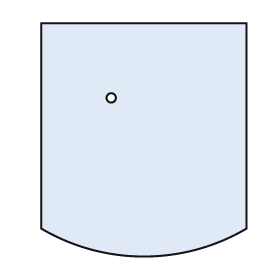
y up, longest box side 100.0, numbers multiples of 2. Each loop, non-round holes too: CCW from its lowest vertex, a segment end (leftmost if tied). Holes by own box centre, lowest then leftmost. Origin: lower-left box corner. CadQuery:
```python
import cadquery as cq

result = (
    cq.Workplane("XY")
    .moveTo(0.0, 12.0)
    .threePointArc((44.0, 0.0), (88.0, 12.0))
    .lineTo(88.0, 100.0)
    .lineTo(0.0, 100.0)
    .close()
    .moveTo(30.0, 68.0)
    .circle(2.0)
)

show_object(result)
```